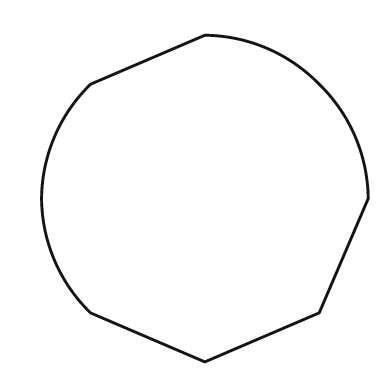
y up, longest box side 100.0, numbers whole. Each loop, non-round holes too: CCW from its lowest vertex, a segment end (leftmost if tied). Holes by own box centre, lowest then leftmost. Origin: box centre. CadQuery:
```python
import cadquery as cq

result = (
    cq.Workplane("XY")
    .moveTo(0.0, -50.0)
    .lineTo(35.0, -35.0)
    .lineTo(50.0, 0.0)
    .threePointArc((46.0, 19.0), (35.0, 35.0))
    .threePointArc((19.0, 46.0), (0.0, 50.0))
    .lineTo(-35.0, 35.0)
    .threePointArc((-46.0, 19.0), (-50.0, 0.0))
    .threePointArc((-46.0, -19.0), (-35.0, -35.0))
    .close()
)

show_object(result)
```